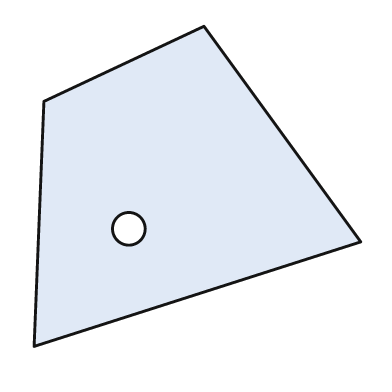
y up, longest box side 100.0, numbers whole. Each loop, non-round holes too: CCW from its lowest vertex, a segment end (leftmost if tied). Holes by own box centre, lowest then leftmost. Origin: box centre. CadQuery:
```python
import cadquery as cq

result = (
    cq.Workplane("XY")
    .moveTo(-50.0, -49.0)
    .lineTo(50.0, -17.0)
    .lineTo(2.0, 49.0)
    .lineTo(-47.0, 26.0)
    .close()
    .moveTo(-21.0, -13.0)
    .circle(5.0)
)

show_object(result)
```